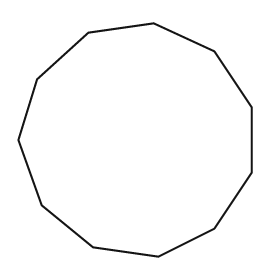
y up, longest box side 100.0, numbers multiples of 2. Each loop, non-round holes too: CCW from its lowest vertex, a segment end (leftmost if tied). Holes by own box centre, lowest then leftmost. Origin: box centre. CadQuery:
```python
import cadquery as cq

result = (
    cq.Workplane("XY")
    .moveTo(10.0, -50.0)
    .lineTo(34.0, -38.0)
    .lineTo(50.0, -14.0)
    .lineTo(50.0, 14.0)
    .lineTo(34.0, 38.0)
    .lineTo(8.0, 50.0)
    .lineTo(-20.0, 46.0)
    .lineTo(-42.0, 26.0)
    .lineTo(-50.0, 0.0)
    .lineTo(-40.0, -28.0)
    .lineTo(-18.0, -46.0)
    .close()
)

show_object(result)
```